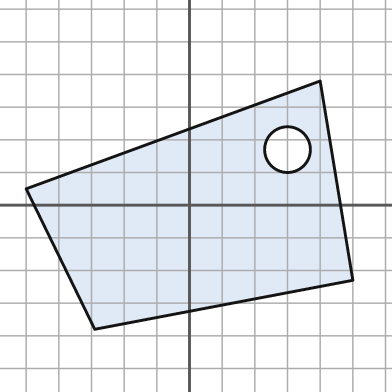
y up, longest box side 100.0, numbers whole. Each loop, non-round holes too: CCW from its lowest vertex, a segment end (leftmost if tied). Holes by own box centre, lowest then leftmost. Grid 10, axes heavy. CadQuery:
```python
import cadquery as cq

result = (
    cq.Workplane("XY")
    .moveTo(-29.0, -38.0)
    .lineTo(50.0, -23.0)
    .lineTo(40.0, 38.0)
    .lineTo(-50.0, 5.0)
    .close()
    .moveTo(30.0, 17.0)
    .circle(7.0)
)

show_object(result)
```